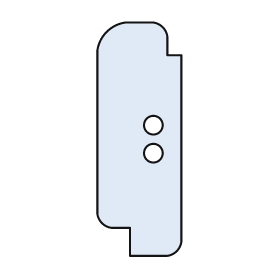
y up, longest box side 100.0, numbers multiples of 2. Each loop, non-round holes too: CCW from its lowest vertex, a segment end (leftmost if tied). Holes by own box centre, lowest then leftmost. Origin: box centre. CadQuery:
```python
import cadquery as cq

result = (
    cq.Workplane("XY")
    .moveTo(-4.0, -50.0)
    .lineTo(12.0, -50.0)
    .threePointArc((16.0, -48.0), (18.0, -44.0))
    .lineTo(18.0, 36.0)
    .lineTo(12.0, 36.0)
    .lineTo(12.0, 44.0)
    .threePointArc((10.0, 48.0), (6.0, 50.0))
    .lineTo(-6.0, 50.0)
    .threePointArc((-14.0, 46.0), (-18.0, 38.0))
    .lineTo(-18.0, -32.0)
    .threePointArc((-16.0, -36.0), (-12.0, -38.0))
    .lineTo(-4.0, -38.0)
    .close()
    .moveTo(6.0, -6.0)
    .circle(4.0)
    .moveTo(6.0, 6.0)
    .circle(4.0)
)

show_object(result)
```